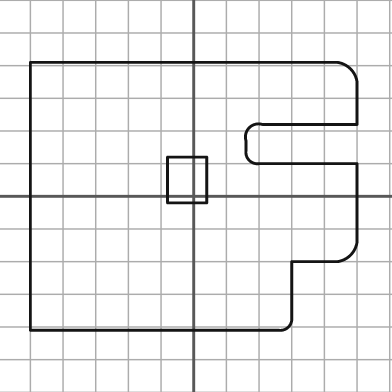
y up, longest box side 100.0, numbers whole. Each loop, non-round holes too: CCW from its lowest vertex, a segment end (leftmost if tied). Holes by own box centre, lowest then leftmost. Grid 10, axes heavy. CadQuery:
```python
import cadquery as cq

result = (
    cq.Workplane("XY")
    .moveTo(-50.0, -41.0)
    .lineTo(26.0, -41.0)
    .threePointArc((29.0, -40.0), (30.0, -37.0))
    .lineTo(30.0, -20.0)
    .lineTo(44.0, -20.0)
    .threePointArc((48.0, -18.0), (50.0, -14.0))
    .lineTo(50.0, 10.0)
    .lineTo(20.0, 10.0)
    .threePointArc((17.0, 11.0), (16.0, 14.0))
    .lineTo(16.0, 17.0)
    .threePointArc((17.0, 21.0), (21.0, 22.0))
    .lineTo(50.0, 22.0)
    .lineTo(50.0, 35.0)
    .threePointArc((48.0, 39.0), (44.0, 41.0))
    .lineTo(-50.0, 41.0)
    .close()
    .moveTo(-8.0, -2.0)
    .lineTo(4.0, -2.0)
    .lineTo(4.0, 12.0)
    .lineTo(-8.0, 12.0)
    .close()
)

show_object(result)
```